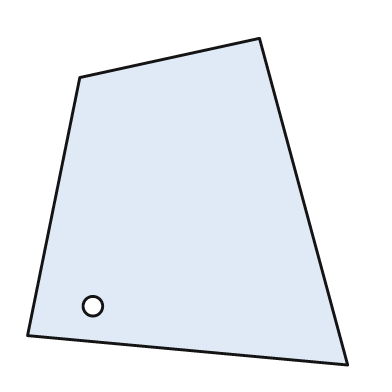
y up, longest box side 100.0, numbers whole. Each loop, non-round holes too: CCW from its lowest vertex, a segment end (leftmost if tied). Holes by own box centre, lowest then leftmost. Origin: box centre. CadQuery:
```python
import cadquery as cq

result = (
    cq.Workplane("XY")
    .moveTo(49.0, -50.0)
    .lineTo(22.0, 50.0)
    .lineTo(-33.0, 38.0)
    .lineTo(-49.0, -41.0)
    .close()
    .moveTo(-29.0, -32.0)
    .circle(3.0)
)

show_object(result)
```